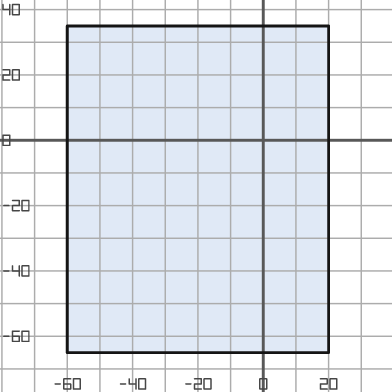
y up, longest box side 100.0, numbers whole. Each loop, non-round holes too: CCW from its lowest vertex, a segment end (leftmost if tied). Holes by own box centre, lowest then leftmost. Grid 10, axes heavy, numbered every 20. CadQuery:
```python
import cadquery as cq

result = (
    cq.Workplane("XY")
    .moveTo(-60.0, -65.0)
    .lineTo(20.0, -65.0)
    .lineTo(20.0, 35.0)
    .lineTo(-60.0, 35.0)
    .close()
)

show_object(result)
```